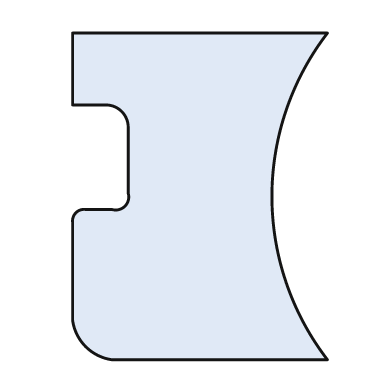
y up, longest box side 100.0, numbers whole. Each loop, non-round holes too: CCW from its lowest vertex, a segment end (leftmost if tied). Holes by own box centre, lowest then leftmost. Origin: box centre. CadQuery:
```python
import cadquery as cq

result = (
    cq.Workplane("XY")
    .moveTo(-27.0, -50.0)
    .lineTo(39.0, -50.0)
    .threePointArc((22.0, 0.0), (39.0, 50.0))
    .lineTo(-39.0, 50.0)
    .lineTo(-39.0, 28.0)
    .lineTo(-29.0, 28.0)
    .threePointArc((-24.0, 26.0), (-22.0, 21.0))
    .lineTo(-22.0, 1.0)
    .threePointArc((-23.0, -3.0), (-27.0, -4.0))
    .lineTo(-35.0, -4.0)
    .threePointArc((-38.0, -5.0), (-39.0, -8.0))
    .lineTo(-39.0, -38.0)
    .threePointArc((-35.0, -46.0), (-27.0, -50.0))
    .close()
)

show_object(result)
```